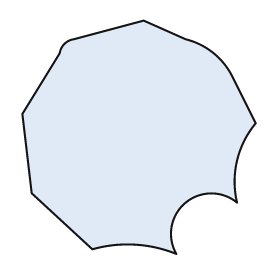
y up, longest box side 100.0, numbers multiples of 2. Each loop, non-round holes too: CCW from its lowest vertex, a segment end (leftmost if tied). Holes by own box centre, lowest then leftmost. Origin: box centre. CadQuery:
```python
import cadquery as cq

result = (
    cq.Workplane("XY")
    .moveTo(16.0, -50.0)
    .threePointArc((20.0, -28.0), (42.0, -28.0))
    .threePointArc((42.0, -10.0), (50.0, 6.0))
    .lineTo(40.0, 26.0)
    .threePointArc((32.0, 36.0), (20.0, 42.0))
    .lineTo(2.0, 50.0)
    .lineTo(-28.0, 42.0)
    .threePointArc((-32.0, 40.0), (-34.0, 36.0))
    .lineTo(-50.0, 10.0)
    .lineTo(-46.0, -24.0)
    .lineTo(-20.0, -48.0)
    .threePointArc((-2.0, -46.0), (16.0, -50.0))
    .close()
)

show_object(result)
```